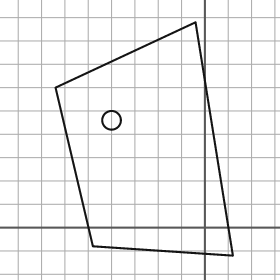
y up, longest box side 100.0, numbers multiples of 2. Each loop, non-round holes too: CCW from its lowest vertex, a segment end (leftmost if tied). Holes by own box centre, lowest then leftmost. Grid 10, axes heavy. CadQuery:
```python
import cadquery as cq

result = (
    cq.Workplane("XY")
    .moveTo(12.0, -12.0)
    .lineTo(-4.0, 88.0)
    .lineTo(-64.0, 60.0)
    .lineTo(-48.0, -8.0)
    .close()
    .moveTo(-40.0, 46.0)
    .circle(4.0)
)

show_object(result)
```